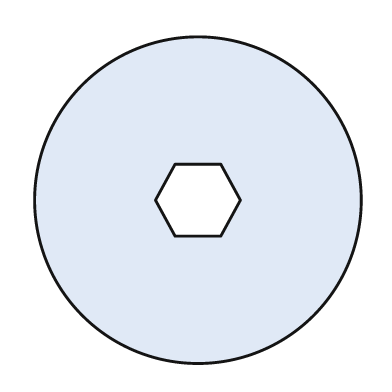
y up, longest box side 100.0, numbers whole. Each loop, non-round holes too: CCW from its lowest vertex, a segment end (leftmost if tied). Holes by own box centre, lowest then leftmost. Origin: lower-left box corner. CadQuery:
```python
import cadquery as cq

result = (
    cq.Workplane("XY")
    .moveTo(50.0, 50.0)
    .circle(50.0)
    .moveTo(43.0, 39.0)
    .lineTo(57.0, 39.0)
    .lineTo(63.0, 50.0)
    .lineTo(57.0, 61.0)
    .lineTo(43.0, 61.0)
    .lineTo(37.0, 50.0)
    .close()
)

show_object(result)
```